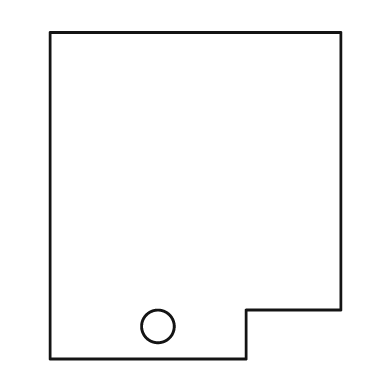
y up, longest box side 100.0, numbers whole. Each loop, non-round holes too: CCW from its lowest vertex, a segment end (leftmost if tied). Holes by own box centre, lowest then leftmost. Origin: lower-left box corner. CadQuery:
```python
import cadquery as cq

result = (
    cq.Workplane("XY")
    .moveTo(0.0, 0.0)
    .lineTo(60.0, 0.0)
    .lineTo(60.0, 15.0)
    .lineTo(89.0, 15.0)
    .lineTo(89.0, 100.0)
    .lineTo(0.0, 100.0)
    .close()
    .moveTo(33.0, 10.0)
    .circle(5.0)
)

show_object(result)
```